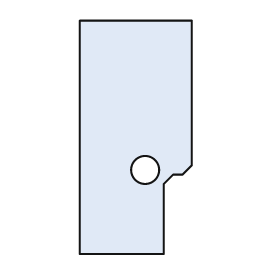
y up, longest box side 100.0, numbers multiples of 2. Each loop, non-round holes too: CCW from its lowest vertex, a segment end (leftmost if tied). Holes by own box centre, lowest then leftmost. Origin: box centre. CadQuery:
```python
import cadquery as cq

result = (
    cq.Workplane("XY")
    .moveTo(-24.0, -50.0)
    .lineTo(12.0, -50.0)
    .lineTo(12.0, -20.0)
    .lineTo(16.0, -16.0)
    .lineTo(20.0, -16.0)
    .lineTo(24.0, -12.0)
    .lineTo(24.0, 50.0)
    .lineTo(-24.0, 50.0)
    .close()
    .moveTo(4.0, -14.0)
    .circle(6.0)
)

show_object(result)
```